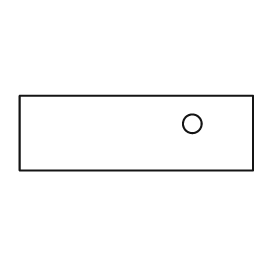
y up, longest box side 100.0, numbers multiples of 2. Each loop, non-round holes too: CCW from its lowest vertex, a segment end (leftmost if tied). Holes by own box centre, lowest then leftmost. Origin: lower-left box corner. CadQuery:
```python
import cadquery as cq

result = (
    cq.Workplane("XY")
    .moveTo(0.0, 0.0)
    .lineTo(100.0, 0.0)
    .lineTo(100.0, 32.0)
    .lineTo(0.0, 32.0)
    .close()
    .moveTo(74.0, 20.0)
    .circle(4.0)
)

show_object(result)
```